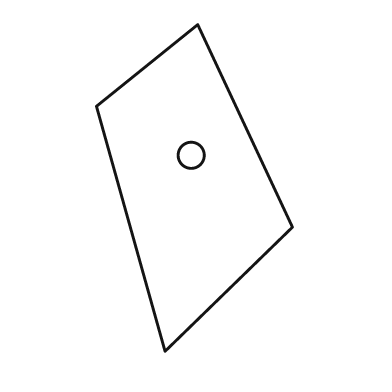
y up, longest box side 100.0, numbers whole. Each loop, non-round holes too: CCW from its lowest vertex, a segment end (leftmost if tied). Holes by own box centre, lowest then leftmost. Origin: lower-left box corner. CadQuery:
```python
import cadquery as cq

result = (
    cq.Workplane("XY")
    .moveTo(21.0, 0.0)
    .lineTo(60.0, 38.0)
    .lineTo(31.0, 100.0)
    .lineTo(0.0, 75.0)
    .close()
    .moveTo(29.0, 60.0)
    .circle(4.0)
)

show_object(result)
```